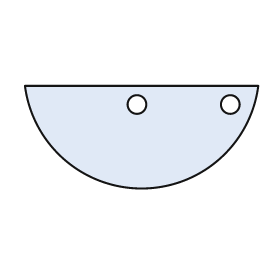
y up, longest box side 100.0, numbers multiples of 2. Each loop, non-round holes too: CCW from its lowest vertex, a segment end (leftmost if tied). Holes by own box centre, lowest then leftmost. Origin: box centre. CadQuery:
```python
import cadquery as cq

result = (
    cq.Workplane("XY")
    .moveTo(-50.0, 22.0)
    .threePointArc((0.0, -22.0), (50.0, 22.0))
    .close()
    .moveTo(-2.0, 14.0)
    .circle(4.0)
    .moveTo(38.0, 14.0)
    .circle(4.0)
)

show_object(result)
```